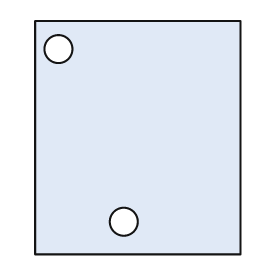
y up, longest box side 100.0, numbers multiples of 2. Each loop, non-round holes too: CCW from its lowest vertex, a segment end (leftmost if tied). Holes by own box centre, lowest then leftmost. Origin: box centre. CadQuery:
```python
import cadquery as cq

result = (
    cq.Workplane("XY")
    .moveTo(-44.0, -50.0)
    .lineTo(44.0, -50.0)
    .lineTo(44.0, 50.0)
    .lineTo(-44.0, 50.0)
    .close()
    .moveTo(-6.0, -36.0)
    .circle(6.0)
    .moveTo(-34.0, 38.0)
    .circle(6.0)
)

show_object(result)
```